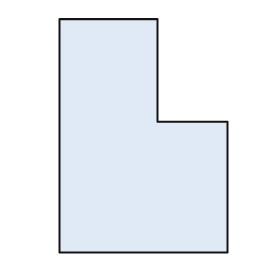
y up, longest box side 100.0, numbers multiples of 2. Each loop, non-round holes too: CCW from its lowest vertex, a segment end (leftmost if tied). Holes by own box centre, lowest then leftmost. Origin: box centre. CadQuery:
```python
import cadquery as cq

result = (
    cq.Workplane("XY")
    .moveTo(-36.0, -50.0)
    .lineTo(36.0, -50.0)
    .lineTo(36.0, 6.0)
    .lineTo(6.0, 6.0)
    .lineTo(6.0, 50.0)
    .lineTo(-36.0, 50.0)
    .close()
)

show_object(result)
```